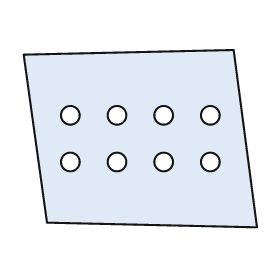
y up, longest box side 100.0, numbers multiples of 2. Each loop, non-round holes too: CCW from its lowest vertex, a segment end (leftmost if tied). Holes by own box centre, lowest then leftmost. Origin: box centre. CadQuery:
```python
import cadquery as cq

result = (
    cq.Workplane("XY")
    .moveTo(50.0, -38.0)
    .lineTo(40.0, 38.0)
    .lineTo(-50.0, 36.0)
    .lineTo(-40.0, -36.0)
    .close()
    .moveTo(-30.0, -10.0)
    .circle(4.0)
    .moveTo(-10.0, -10.0)
    .circle(4.0)
    .moveTo(10.0, -10.0)
    .circle(4.0)
    .moveTo(30.0, -10.0)
    .circle(4.0)
    .moveTo(-30.0, 10.0)
    .circle(4.0)
    .moveTo(-10.0, 10.0)
    .circle(4.0)
    .moveTo(10.0, 10.0)
    .circle(4.0)
    .moveTo(30.0, 10.0)
    .circle(4.0)
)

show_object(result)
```